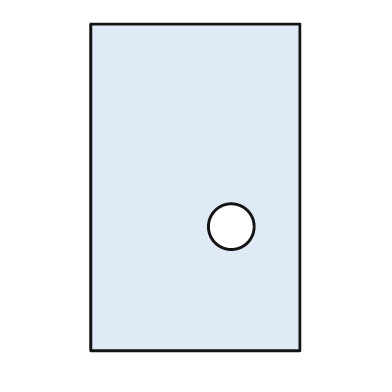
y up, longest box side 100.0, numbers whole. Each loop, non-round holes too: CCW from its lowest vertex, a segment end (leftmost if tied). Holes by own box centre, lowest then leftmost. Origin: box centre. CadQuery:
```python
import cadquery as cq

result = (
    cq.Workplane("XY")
    .moveTo(-32.0, -50.0)
    .lineTo(32.0, -50.0)
    .lineTo(32.0, 50.0)
    .lineTo(-32.0, 50.0)
    .close()
    .moveTo(11.0, -12.0)
    .circle(7.0)
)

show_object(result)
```